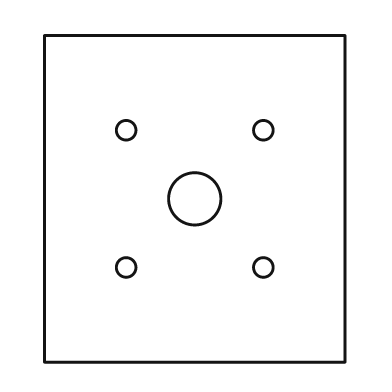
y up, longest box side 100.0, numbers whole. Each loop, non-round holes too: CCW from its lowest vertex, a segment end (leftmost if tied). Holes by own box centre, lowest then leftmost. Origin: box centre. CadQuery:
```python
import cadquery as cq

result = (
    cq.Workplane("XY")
    .moveTo(-46.0, -50.0)
    .lineTo(46.0, -50.0)
    .lineTo(46.0, 50.0)
    .lineTo(-46.0, 50.0)
    .close()
    .moveTo(-21.0, -21.0)
    .circle(3.0)
    .moveTo(21.0, -21.0)
    .circle(3.0)
    .moveTo(0.0, 0.0)
    .circle(8.0)
    .moveTo(-21.0, 21.0)
    .circle(3.0)
    .moveTo(21.0, 21.0)
    .circle(3.0)
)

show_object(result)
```